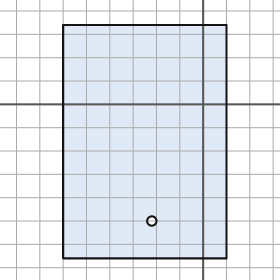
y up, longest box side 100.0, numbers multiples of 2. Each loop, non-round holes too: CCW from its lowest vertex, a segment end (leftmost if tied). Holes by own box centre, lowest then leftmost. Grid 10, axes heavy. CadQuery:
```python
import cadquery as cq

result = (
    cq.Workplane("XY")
    .moveTo(-60.0, -66.0)
    .lineTo(10.0, -66.0)
    .lineTo(10.0, 34.0)
    .lineTo(-60.0, 34.0)
    .close()
    .moveTo(-22.0, -50.0)
    .circle(2.0)
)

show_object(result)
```